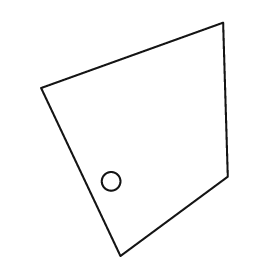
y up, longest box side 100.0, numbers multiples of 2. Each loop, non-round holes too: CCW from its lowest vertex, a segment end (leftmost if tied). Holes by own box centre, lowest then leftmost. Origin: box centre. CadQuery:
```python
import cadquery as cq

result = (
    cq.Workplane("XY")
    .moveTo(-6.0, -50.0)
    .lineTo(40.0, -16.0)
    .lineTo(38.0, 50.0)
    .lineTo(-40.0, 22.0)
    .close()
    .moveTo(-10.0, -18.0)
    .circle(4.0)
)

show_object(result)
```